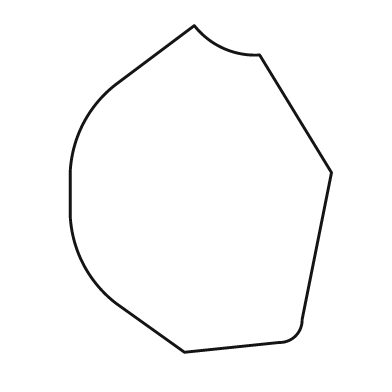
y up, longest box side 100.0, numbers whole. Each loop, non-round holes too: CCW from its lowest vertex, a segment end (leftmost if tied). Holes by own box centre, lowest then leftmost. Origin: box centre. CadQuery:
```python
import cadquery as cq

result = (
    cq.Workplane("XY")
    .moveTo(-5.0, -50.0)
    .lineTo(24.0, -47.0)
    .threePointArc((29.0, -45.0), (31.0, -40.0))
    .lineTo(40.0, 5.0)
    .lineTo(18.0, 41.0)
    .threePointArc((7.0, 43.0), (-2.0, 50.0))
    .lineTo(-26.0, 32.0)
    .threePointArc((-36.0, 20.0), (-40.0, 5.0))
    .lineTo(-40.0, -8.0)
    .threePointArc((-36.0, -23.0), (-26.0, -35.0))
    .close()
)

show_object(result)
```